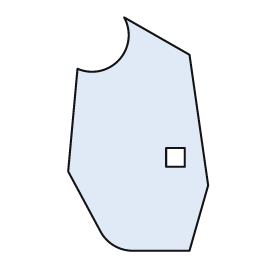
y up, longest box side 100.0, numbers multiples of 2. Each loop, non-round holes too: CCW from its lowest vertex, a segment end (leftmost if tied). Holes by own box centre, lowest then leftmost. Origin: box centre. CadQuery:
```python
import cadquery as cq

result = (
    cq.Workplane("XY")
    .moveTo(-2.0, -50.0)
    .lineTo(22.0, -50.0)
    .lineTo(30.0, -22.0)
    .lineTo(22.0, 34.0)
    .lineTo(-6.0, 50.0)
    .threePointArc((-8.0, 32.0), (-26.0, 28.0))
    .lineTo(-30.0, -16.0)
    .lineTo(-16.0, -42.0)
    .threePointArc((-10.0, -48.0), (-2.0, -50.0))
    .close()
    .moveTo(12.0, -14.0)
    .lineTo(20.0, -14.0)
    .lineTo(20.0, -6.0)
    .lineTo(12.0, -6.0)
    .close()
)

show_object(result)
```